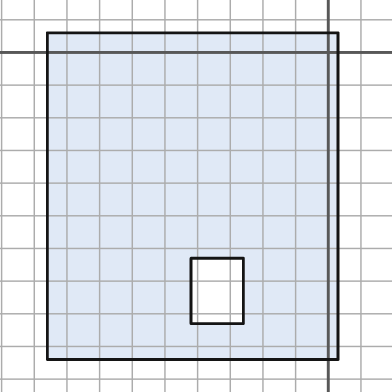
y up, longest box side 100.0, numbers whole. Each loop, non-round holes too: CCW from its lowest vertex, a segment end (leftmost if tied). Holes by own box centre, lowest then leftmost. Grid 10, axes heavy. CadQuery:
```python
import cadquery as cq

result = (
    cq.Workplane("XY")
    .moveTo(-86.0, -94.0)
    .lineTo(3.0, -94.0)
    .lineTo(3.0, 6.0)
    .lineTo(-86.0, 6.0)
    .close()
    .moveTo(-42.0, -83.0)
    .lineTo(-26.0, -83.0)
    .lineTo(-26.0, -63.0)
    .lineTo(-42.0, -63.0)
    .close()
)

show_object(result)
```